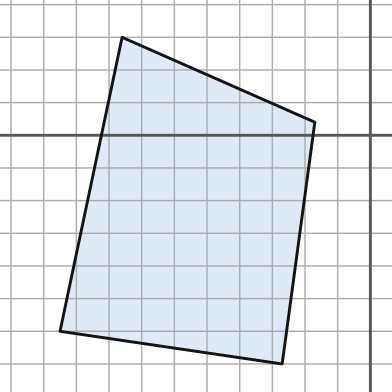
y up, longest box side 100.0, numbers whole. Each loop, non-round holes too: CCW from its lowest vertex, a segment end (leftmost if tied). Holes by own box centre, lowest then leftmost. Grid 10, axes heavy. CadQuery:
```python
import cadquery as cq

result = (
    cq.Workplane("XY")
    .moveTo(-27.0, -70.0)
    .lineTo(-17.0, 4.0)
    .lineTo(-76.0, 30.0)
    .lineTo(-95.0, -60.0)
    .close()
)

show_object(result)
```